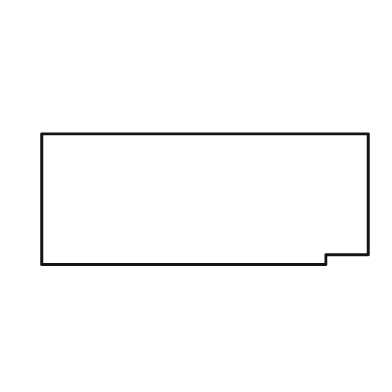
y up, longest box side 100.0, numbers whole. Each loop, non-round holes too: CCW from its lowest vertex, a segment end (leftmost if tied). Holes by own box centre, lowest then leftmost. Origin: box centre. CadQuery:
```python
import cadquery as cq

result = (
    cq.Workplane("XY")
    .moveTo(-50.0, -20.0)
    .lineTo(37.0, -20.0)
    .lineTo(37.0, -17.0)
    .lineTo(50.0, -17.0)
    .lineTo(50.0, 20.0)
    .lineTo(-50.0, 20.0)
    .close()
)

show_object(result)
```